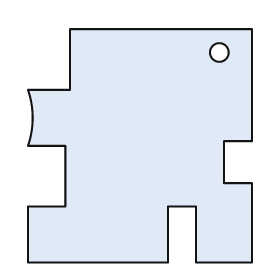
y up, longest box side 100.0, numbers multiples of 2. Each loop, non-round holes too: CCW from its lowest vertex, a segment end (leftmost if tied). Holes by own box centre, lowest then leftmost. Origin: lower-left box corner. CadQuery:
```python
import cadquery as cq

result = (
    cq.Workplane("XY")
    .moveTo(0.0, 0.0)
    .lineTo(60.0, 0.0)
    .lineTo(60.0, 24.0)
    .lineTo(72.0, 24.0)
    .lineTo(72.0, 0.0)
    .lineTo(96.0, 0.0)
    .lineTo(96.0, 34.0)
    .lineTo(84.0, 34.0)
    .lineTo(84.0, 52.0)
    .lineTo(96.0, 52.0)
    .lineTo(96.0, 100.0)
    .lineTo(18.0, 100.0)
    .lineTo(18.0, 74.0)
    .lineTo(0.0, 74.0)
    .threePointArc((2.0, 62.0), (0.0, 50.0))
    .lineTo(16.0, 50.0)
    .lineTo(16.0, 24.0)
    .lineTo(0.0, 24.0)
    .close()
    .moveTo(82.0, 90.0)
    .circle(4.0)
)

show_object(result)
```